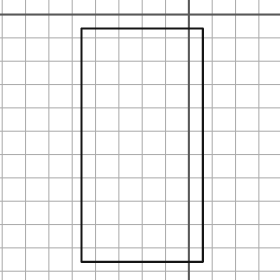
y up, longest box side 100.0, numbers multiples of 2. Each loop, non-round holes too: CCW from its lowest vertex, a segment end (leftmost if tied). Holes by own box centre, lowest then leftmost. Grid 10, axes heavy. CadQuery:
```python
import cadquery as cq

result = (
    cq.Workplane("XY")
    .moveTo(-46.0, -106.0)
    .lineTo(6.0, -106.0)
    .lineTo(6.0, -6.0)
    .lineTo(-46.0, -6.0)
    .close()
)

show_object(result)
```